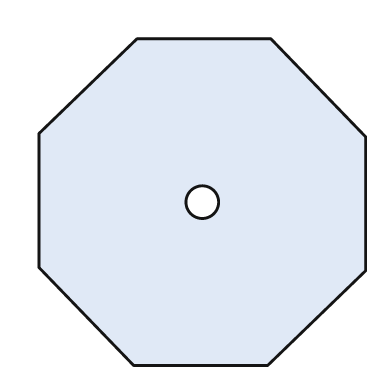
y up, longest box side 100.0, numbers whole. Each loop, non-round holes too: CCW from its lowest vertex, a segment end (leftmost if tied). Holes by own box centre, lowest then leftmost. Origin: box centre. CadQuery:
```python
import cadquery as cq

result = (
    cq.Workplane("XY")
    .moveTo(-21.0, -50.0)
    .lineTo(20.0, -50.0)
    .lineTo(50.0, -21.0)
    .lineTo(50.0, 20.0)
    .lineTo(21.0, 50.0)
    .lineTo(-20.0, 50.0)
    .lineTo(-50.0, 21.0)
    .lineTo(-50.0, -20.0)
    .close()
    .moveTo(0.0, 0.0)
    .circle(5.0)
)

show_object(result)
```